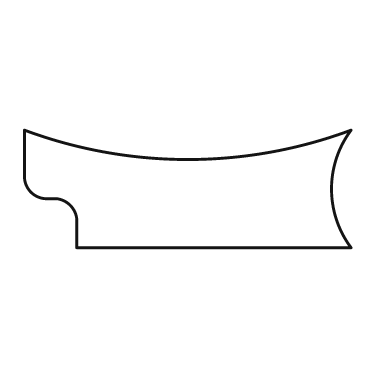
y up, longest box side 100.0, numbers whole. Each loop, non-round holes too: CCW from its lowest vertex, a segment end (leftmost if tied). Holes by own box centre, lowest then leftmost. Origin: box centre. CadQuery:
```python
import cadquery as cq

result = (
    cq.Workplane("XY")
    .moveTo(-34.0, -18.0)
    .lineTo(50.0, -18.0)
    .threePointArc((44.0, 0.0), (50.0, 18.0))
    .threePointArc((0.0, 9.0), (-50.0, 18.0))
    .lineTo(-50.0, 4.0)
    .threePointArc((-48.0, -1.0), (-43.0, -3.0))
    .lineTo(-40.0, -3.0)
    .threePointArc((-36.0, -5.0), (-34.0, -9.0))
    .close()
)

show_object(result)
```